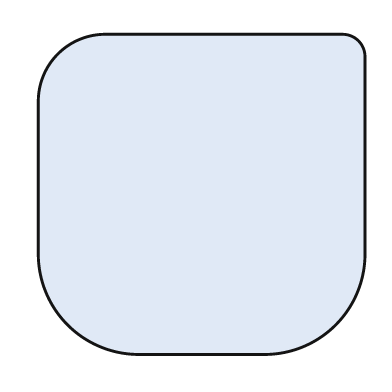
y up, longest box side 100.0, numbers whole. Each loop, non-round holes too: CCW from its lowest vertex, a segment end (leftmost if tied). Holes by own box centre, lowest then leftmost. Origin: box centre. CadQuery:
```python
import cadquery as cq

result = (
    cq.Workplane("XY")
    .moveTo(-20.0, -49.0)
    .lineTo(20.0, -49.0)
    .threePointArc((41.0, -40.0), (50.0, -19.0))
    .lineTo(50.0, 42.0)
    .threePointArc((48.0, 47.0), (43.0, 49.0))
    .lineTo(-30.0, 49.0)
    .threePointArc((-44.0, 43.0), (-50.0, 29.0))
    .lineTo(-50.0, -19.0)
    .threePointArc((-41.0, -40.0), (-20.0, -49.0))
    .close()
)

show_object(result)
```